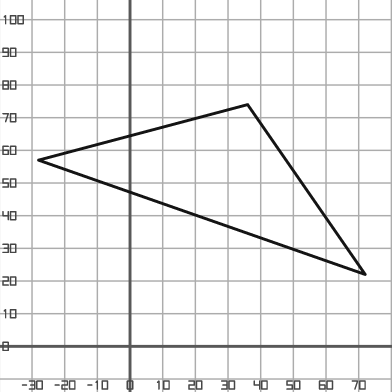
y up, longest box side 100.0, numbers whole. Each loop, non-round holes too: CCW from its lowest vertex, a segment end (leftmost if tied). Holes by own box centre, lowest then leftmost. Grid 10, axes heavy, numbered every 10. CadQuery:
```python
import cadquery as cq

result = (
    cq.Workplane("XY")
    .moveTo(72.0, 22.0)
    .lineTo(36.0, 74.0)
    .lineTo(-28.0, 57.0)
    .close()
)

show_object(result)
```